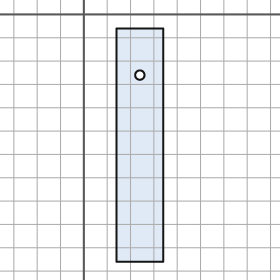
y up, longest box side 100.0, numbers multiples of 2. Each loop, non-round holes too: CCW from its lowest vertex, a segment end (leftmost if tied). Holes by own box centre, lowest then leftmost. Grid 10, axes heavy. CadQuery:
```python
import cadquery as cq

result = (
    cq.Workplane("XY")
    .moveTo(14.0, -106.0)
    .lineTo(34.0, -106.0)
    .lineTo(34.0, -6.0)
    .lineTo(14.0, -6.0)
    .close()
    .moveTo(24.0, -26.0)
    .circle(2.0)
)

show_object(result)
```